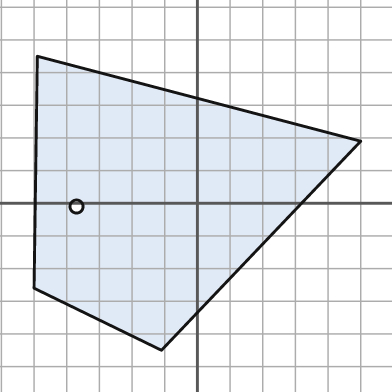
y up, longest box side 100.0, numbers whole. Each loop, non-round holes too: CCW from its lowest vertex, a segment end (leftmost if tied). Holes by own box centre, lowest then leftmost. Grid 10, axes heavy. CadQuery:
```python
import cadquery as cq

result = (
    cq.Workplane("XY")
    .moveTo(-11.0, -45.0)
    .lineTo(50.0, 19.0)
    .lineTo(-49.0, 45.0)
    .lineTo(-50.0, -26.0)
    .close()
    .moveTo(-37.0, -1.0)
    .circle(2.0)
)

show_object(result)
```